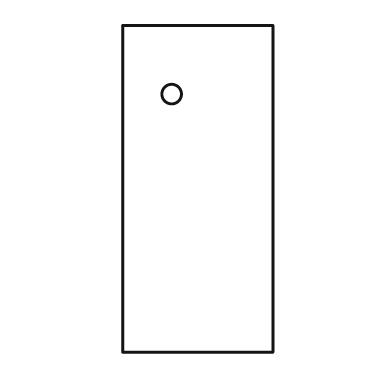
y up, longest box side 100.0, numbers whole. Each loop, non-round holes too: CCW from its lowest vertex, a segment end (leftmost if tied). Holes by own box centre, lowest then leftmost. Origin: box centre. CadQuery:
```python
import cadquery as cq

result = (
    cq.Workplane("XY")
    .moveTo(-23.0, -50.0)
    .lineTo(23.0, -50.0)
    .lineTo(23.0, 50.0)
    .lineTo(-23.0, 50.0)
    .close()
    .moveTo(-8.0, 29.0)
    .circle(3.0)
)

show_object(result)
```